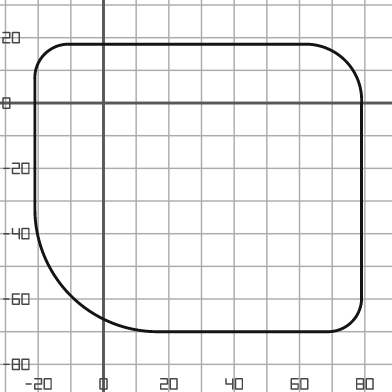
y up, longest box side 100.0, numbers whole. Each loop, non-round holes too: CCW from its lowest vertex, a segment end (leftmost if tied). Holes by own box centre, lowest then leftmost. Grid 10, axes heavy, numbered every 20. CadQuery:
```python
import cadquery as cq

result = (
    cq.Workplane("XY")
    .moveTo(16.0, -70.0)
    .lineTo(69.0, -70.0)
    .threePointArc((76.0, -67.0), (79.0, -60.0))
    .lineTo(79.0, 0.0)
    .threePointArc((74.0, 13.0), (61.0, 18.0))
    .lineTo(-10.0, 18.0)
    .threePointArc((-18.0, 15.0), (-21.0, 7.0))
    .lineTo(-21.0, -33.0)
    .threePointArc((-10.0, -59.0), (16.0, -70.0))
    .close()
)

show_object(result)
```